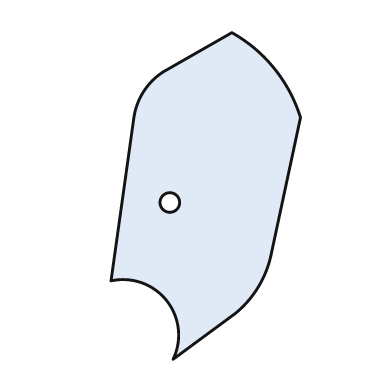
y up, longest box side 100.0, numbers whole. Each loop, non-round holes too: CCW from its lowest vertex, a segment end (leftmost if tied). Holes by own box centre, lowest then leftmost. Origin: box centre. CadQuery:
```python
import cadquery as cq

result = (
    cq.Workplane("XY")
    .moveTo(-10.0, -50.0)
    .lineTo(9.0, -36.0)
    .threePointArc((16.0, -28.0), (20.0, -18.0))
    .lineTo(29.0, 24.0)
    .threePointArc((21.0, 39.0), (8.0, 50.0))
    .lineTo(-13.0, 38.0)
    .threePointArc((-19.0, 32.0), (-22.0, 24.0))
    .lineTo(-29.0, -26.0)
    .threePointArc((-12.0, -32.0), (-10.0, -50.0))
    .close()
    .moveTo(-11.0, -2.0)
    .circle(3.0)
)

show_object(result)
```